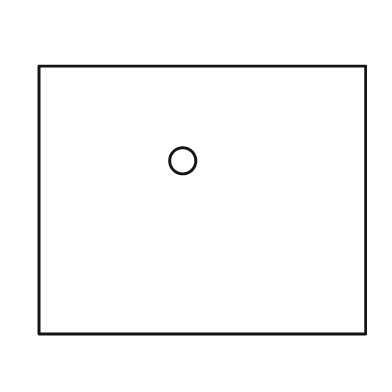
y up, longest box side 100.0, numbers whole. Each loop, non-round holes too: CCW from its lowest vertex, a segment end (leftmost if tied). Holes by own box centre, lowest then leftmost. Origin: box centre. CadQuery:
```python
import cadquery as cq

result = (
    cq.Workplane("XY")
    .moveTo(-50.0, -41.0)
    .lineTo(50.0, -41.0)
    .lineTo(50.0, 41.0)
    .lineTo(-50.0, 41.0)
    .close()
    .moveTo(-6.0, 12.0)
    .circle(4.0)
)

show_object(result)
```